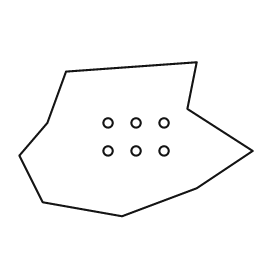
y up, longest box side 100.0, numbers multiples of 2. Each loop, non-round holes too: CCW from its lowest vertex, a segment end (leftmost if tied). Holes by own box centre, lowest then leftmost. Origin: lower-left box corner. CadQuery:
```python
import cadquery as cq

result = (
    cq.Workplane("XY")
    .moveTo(44.0, 0.0)
    .lineTo(76.0, 12.0)
    .lineTo(100.0, 28.0)
    .lineTo(72.0, 46.0)
    .lineTo(76.0, 66.0)
    .lineTo(20.0, 62.0)
    .lineTo(12.0, 40.0)
    .lineTo(0.0, 26.0)
    .lineTo(10.0, 6.0)
    .close()
    .moveTo(38.0, 28.0)
    .circle(2.0)
    .moveTo(50.0, 28.0)
    .circle(2.0)
    .moveTo(62.0, 28.0)
    .circle(2.0)
    .moveTo(38.0, 40.0)
    .circle(2.0)
    .moveTo(50.0, 40.0)
    .circle(2.0)
    .moveTo(62.0, 40.0)
    .circle(2.0)
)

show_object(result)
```